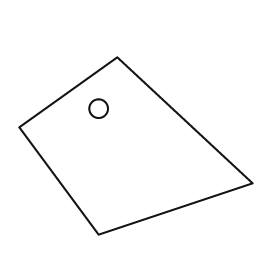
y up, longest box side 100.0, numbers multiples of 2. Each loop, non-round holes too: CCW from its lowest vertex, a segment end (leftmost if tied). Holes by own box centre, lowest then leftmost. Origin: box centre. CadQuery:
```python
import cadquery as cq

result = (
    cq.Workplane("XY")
    .moveTo(-16.0, -38.0)
    .lineTo(50.0, -16.0)
    .lineTo(-8.0, 38.0)
    .lineTo(-50.0, 8.0)
    .close()
    .moveTo(-16.0, 16.0)
    .circle(4.0)
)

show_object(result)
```